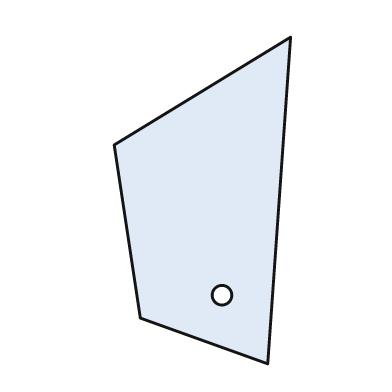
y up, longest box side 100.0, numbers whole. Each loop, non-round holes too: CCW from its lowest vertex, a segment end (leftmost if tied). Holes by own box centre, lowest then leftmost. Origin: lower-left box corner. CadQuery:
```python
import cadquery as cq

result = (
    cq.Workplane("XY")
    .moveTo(47.0, 0.0)
    .lineTo(54.0, 100.0)
    .lineTo(0.0, 67.0)
    .lineTo(8.0, 14.0)
    .close()
    .moveTo(33.0, 21.0)
    .circle(3.0)
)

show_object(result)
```